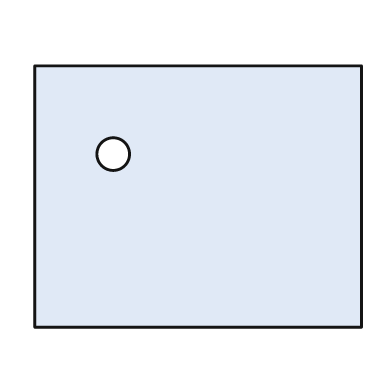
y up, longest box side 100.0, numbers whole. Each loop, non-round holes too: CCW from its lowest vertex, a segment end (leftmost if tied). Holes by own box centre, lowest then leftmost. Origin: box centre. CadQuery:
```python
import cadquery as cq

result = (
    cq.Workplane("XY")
    .moveTo(-50.0, -40.0)
    .lineTo(50.0, -40.0)
    .lineTo(50.0, 40.0)
    .lineTo(-50.0, 40.0)
    .close()
    .moveTo(-26.0, 13.0)
    .circle(5.0)
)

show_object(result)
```